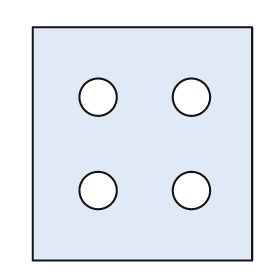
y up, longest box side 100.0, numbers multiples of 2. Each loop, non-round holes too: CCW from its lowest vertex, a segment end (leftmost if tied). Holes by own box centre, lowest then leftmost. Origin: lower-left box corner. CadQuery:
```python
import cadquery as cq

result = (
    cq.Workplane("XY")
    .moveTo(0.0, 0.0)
    .lineTo(94.0, 0.0)
    .lineTo(94.0, 100.0)
    .lineTo(0.0, 100.0)
    .close()
    .moveTo(28.0, 30.0)
    .circle(8.0)
    .moveTo(68.0, 30.0)
    .circle(8.0)
    .moveTo(28.0, 70.0)
    .circle(8.0)
    .moveTo(68.0, 70.0)
    .circle(8.0)
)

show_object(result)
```